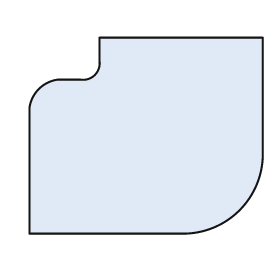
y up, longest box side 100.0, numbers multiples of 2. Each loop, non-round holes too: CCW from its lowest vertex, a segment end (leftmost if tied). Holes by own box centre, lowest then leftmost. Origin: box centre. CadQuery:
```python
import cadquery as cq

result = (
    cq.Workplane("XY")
    .moveTo(-50.0, -42.0)
    .lineTo(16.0, -42.0)
    .threePointArc((40.0, -32.0), (50.0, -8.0))
    .lineTo(50.0, 42.0)
    .lineTo(-20.0, 42.0)
    .lineTo(-20.0, 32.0)
    .threePointArc((-22.0, 26.0), (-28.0, 24.0))
    .lineTo(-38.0, 24.0)
    .threePointArc((-46.0, 20.0), (-50.0, 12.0))
    .close()
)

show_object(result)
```